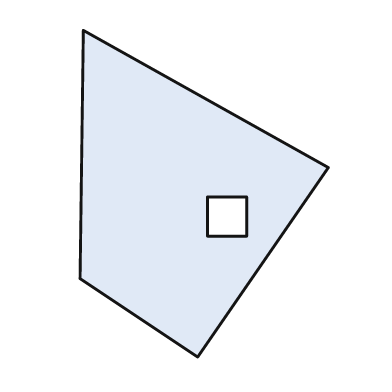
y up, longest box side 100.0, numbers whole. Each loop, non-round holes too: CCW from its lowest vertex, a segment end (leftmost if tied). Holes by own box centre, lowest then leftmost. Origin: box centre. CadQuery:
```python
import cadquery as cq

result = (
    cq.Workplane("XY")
    .moveTo(-2.0, -50.0)
    .lineTo(38.0, 8.0)
    .lineTo(-37.0, 50.0)
    .lineTo(-38.0, -26.0)
    .close()
    .moveTo(1.0, -13.0)
    .lineTo(13.0, -13.0)
    .lineTo(13.0, -1.0)
    .lineTo(1.0, -1.0)
    .close()
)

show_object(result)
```